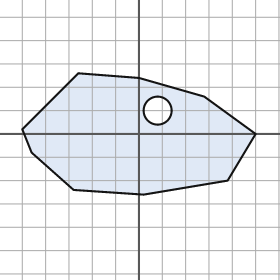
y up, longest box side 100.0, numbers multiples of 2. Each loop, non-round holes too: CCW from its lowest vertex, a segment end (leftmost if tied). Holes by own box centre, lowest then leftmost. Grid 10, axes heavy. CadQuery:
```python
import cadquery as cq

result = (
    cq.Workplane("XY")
    .moveTo(2.0, -26.0)
    .lineTo(38.0, -20.0)
    .lineTo(50.0, 0.0)
    .lineTo(28.0, 16.0)
    .lineTo(0.0, 24.0)
    .lineTo(-26.0, 26.0)
    .lineTo(-50.0, 2.0)
    .lineTo(-46.0, -8.0)
    .lineTo(-28.0, -24.0)
    .close()
    .moveTo(8.0, 10.0)
    .circle(6.0)
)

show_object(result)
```